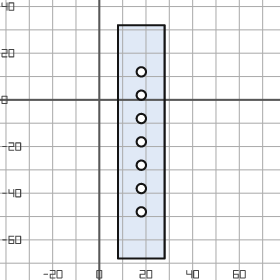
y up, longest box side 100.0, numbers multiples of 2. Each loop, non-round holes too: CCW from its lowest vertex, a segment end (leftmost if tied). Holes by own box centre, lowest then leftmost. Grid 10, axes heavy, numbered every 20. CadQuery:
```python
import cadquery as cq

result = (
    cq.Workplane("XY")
    .moveTo(8.0, -68.0)
    .lineTo(28.0, -68.0)
    .lineTo(28.0, 32.0)
    .lineTo(8.0, 32.0)
    .close()
    .moveTo(18.0, -48.0)
    .circle(2.0)
    .moveTo(18.0, -38.0)
    .circle(2.0)
    .moveTo(18.0, -28.0)
    .circle(2.0)
    .moveTo(18.0, -18.0)
    .circle(2.0)
    .moveTo(18.0, -8.0)
    .circle(2.0)
    .moveTo(18.0, 2.0)
    .circle(2.0)
    .moveTo(18.0, 12.0)
    .circle(2.0)
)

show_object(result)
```